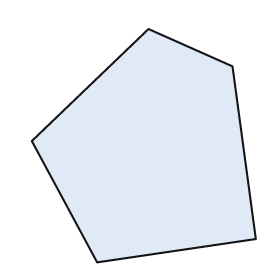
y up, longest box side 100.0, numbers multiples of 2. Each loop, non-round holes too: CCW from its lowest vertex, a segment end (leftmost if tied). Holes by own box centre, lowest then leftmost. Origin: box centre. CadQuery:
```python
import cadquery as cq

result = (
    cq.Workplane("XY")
    .moveTo(-20.0, -50.0)
    .lineTo(48.0, -40.0)
    .lineTo(38.0, 34.0)
    .lineTo(2.0, 50.0)
    .lineTo(-48.0, 2.0)
    .close()
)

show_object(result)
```